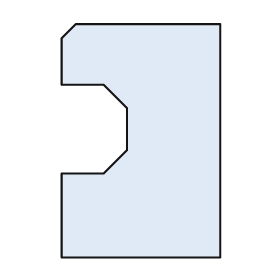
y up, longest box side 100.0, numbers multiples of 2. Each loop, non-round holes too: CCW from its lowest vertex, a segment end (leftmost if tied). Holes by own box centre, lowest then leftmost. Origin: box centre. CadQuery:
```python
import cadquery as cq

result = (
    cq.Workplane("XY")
    .moveTo(-34.0, -50.0)
    .lineTo(34.0, -50.0)
    .lineTo(34.0, 50.0)
    .lineTo(-28.0, 50.0)
    .lineTo(-34.0, 44.0)
    .lineTo(-34.0, 24.0)
    .lineTo(-16.0, 24.0)
    .lineTo(-6.0, 14.0)
    .lineTo(-6.0, -4.0)
    .lineTo(-16.0, -14.0)
    .lineTo(-34.0, -14.0)
    .close()
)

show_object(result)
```